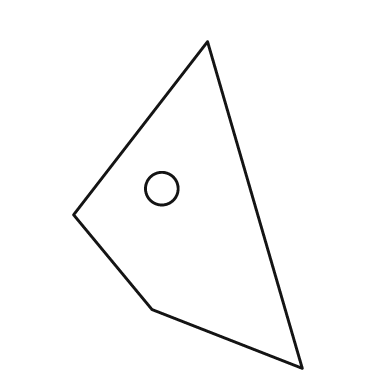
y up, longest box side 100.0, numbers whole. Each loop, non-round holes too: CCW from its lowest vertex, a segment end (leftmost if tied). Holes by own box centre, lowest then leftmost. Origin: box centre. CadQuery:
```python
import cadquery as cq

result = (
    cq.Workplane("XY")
    .moveTo(35.0, -50.0)
    .lineTo(6.0, 50.0)
    .lineTo(-35.0, -3.0)
    .lineTo(-11.0, -32.0)
    .close()
    .moveTo(-8.0, 5.0)
    .circle(5.0)
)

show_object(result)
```